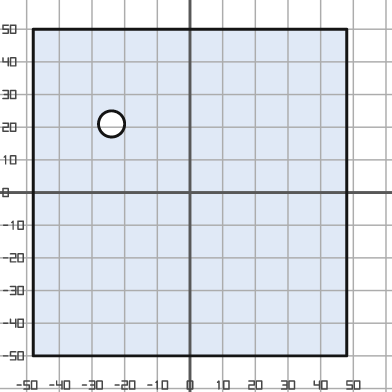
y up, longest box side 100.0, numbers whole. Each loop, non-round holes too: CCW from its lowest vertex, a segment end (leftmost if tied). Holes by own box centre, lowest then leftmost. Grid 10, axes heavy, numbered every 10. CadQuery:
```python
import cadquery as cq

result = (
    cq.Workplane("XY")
    .moveTo(-48.0, -50.0)
    .lineTo(48.0, -50.0)
    .lineTo(48.0, 50.0)
    .lineTo(-48.0, 50.0)
    .close()
    .moveTo(-24.0, 21.0)
    .circle(4.0)
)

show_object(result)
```